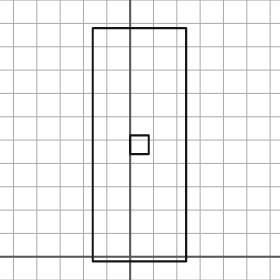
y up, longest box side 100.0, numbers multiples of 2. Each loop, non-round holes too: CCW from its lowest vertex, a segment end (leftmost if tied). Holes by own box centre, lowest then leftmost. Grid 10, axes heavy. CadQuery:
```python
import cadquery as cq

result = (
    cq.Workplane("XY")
    .moveTo(-16.0, -2.0)
    .lineTo(24.0, -2.0)
    .lineTo(24.0, 98.0)
    .lineTo(-16.0, 98.0)
    .close()
    .moveTo(0.0, 44.0)
    .lineTo(8.0, 44.0)
    .lineTo(8.0, 52.0)
    .lineTo(0.0, 52.0)
    .close()
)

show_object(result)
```